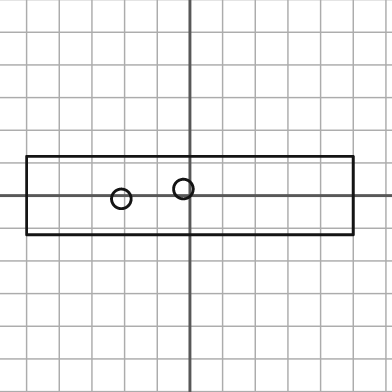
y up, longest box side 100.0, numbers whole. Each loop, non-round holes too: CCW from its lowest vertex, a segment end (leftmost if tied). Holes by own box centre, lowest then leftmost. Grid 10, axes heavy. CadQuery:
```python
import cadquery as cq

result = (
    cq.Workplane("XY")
    .moveTo(-50.0, -12.0)
    .lineTo(50.0, -12.0)
    .lineTo(50.0, 12.0)
    .lineTo(-50.0, 12.0)
    .close()
    .moveTo(-21.0, -1.0)
    .circle(3.0)
    .moveTo(-2.0, 2.0)
    .circle(3.0)
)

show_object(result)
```